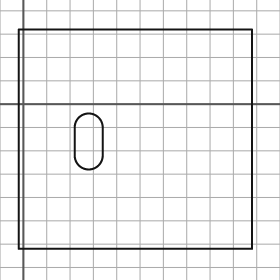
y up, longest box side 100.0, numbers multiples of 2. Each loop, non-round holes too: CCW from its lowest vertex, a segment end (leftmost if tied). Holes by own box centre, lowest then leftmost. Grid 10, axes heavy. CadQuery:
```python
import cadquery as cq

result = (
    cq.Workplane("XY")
    .moveTo(-2.0, -62.0)
    .lineTo(98.0, -62.0)
    .lineTo(98.0, 32.0)
    .lineTo(-2.0, 32.0)
    .close()
    .moveTo(22.0, -22.0)
    .threePointArc((28.0, -28.0), (34.0, -22.0))
    .lineTo(34.0, -10.0)
    .threePointArc((28.0, -4.0), (22.0, -10.0))
    .close()
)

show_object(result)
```